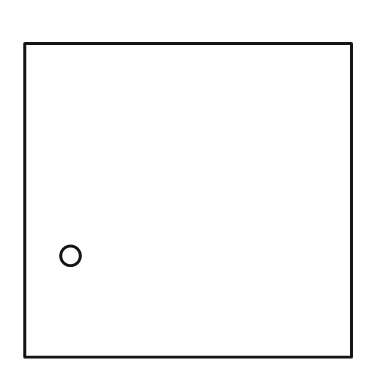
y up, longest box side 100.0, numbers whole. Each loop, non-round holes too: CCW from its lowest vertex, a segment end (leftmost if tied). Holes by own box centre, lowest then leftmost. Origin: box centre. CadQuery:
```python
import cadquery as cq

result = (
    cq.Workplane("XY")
    .moveTo(-50.0, -48.0)
    .lineTo(50.0, -48.0)
    .lineTo(50.0, 48.0)
    .lineTo(-50.0, 48.0)
    .close()
    .moveTo(-36.0, -17.0)
    .circle(3.0)
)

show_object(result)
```